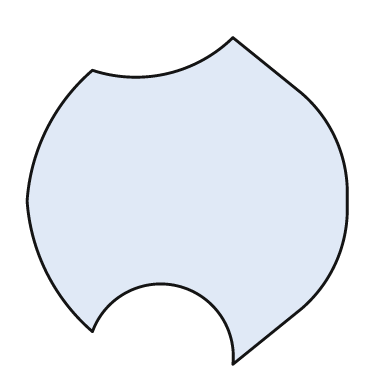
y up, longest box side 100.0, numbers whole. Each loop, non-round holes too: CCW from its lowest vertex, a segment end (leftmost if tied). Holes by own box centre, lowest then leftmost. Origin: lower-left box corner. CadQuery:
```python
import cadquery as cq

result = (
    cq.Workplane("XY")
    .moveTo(63.0, 0.0)
    .lineTo(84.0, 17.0)
    .threePointArc((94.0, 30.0), (98.0, 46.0))
    .lineTo(98.0, 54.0)
    .threePointArc((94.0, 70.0), (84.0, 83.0))
    .lineTo(63.0, 100.0)
    .threePointArc((43.0, 89.0), (20.0, 90.0))
    .threePointArc((6.0, 72.0), (0.0, 50.0))
    .threePointArc((6.0, 28.0), (20.0, 10.0))
    .threePointArc((46.0, 24.0), (63.0, 0.0))
    .close()
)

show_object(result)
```